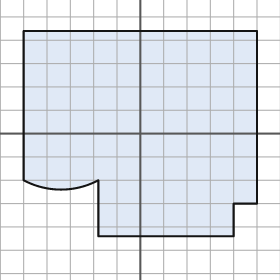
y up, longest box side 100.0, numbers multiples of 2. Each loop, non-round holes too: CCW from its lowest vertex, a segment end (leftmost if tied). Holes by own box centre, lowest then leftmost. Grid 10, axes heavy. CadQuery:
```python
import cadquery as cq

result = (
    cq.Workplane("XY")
    .moveTo(-18.0, -44.0)
    .lineTo(40.0, -44.0)
    .lineTo(40.0, -30.0)
    .lineTo(50.0, -30.0)
    .lineTo(50.0, 44.0)
    .lineTo(-50.0, 44.0)
    .lineTo(-50.0, -20.0)
    .threePointArc((-34.0, -24.0), (-18.0, -20.0))
    .close()
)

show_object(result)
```